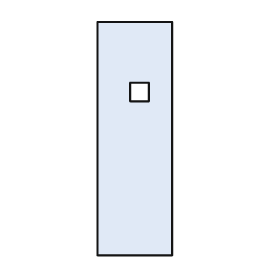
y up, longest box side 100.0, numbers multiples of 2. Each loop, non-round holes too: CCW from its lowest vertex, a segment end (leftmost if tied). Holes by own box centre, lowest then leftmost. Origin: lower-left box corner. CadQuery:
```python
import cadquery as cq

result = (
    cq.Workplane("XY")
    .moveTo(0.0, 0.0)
    .lineTo(32.0, 0.0)
    .lineTo(32.0, 100.0)
    .lineTo(0.0, 100.0)
    .close()
    .moveTo(14.0, 66.0)
    .lineTo(22.0, 66.0)
    .lineTo(22.0, 74.0)
    .lineTo(14.0, 74.0)
    .close()
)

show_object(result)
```